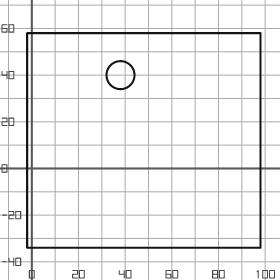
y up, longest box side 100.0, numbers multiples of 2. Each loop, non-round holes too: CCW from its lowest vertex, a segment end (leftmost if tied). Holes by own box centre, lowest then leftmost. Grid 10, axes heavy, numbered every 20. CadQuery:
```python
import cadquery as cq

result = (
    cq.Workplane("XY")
    .moveTo(-2.0, -34.0)
    .lineTo(98.0, -34.0)
    .lineTo(98.0, 58.0)
    .lineTo(-2.0, 58.0)
    .close()
    .moveTo(38.0, 40.0)
    .circle(6.0)
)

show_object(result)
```